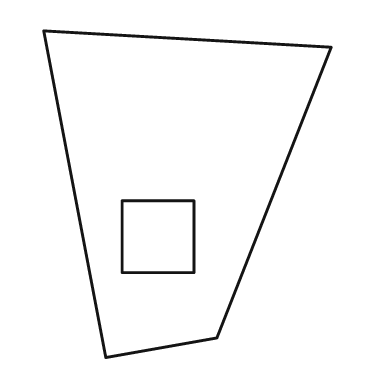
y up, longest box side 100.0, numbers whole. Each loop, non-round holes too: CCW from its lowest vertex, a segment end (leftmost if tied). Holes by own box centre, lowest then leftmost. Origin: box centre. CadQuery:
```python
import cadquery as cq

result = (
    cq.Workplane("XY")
    .moveTo(-25.0, -50.0)
    .lineTo(9.0, -44.0)
    .lineTo(44.0, 45.0)
    .lineTo(-44.0, 50.0)
    .close()
    .moveTo(-20.0, -24.0)
    .lineTo(2.0, -24.0)
    .lineTo(2.0, -2.0)
    .lineTo(-20.0, -2.0)
    .close()
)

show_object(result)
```